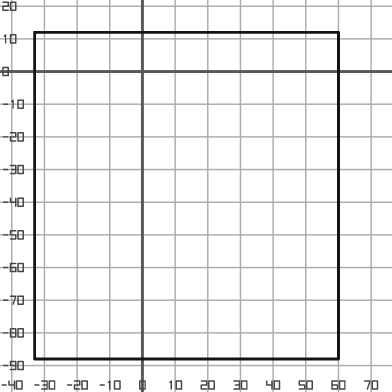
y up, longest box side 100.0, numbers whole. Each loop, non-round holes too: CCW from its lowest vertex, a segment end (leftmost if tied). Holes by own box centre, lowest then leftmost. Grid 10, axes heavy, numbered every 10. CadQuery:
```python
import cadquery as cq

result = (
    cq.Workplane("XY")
    .moveTo(-33.0, -88.0)
    .lineTo(60.0, -88.0)
    .lineTo(60.0, 12.0)
    .lineTo(-33.0, 12.0)
    .close()
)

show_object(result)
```